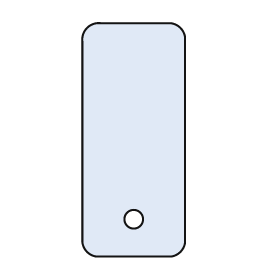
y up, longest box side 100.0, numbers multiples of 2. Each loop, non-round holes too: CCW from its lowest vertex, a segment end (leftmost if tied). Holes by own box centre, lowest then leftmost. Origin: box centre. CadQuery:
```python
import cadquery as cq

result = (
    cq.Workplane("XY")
    .moveTo(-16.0, -50.0)
    .lineTo(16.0, -50.0)
    .threePointArc((20.0, -48.0), (22.0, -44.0))
    .lineTo(22.0, 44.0)
    .threePointArc((20.0, 48.0), (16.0, 50.0))
    .lineTo(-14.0, 50.0)
    .threePointArc((-20.0, 48.0), (-22.0, 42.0))
    .lineTo(-22.0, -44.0)
    .threePointArc((-20.0, -48.0), (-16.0, -50.0))
    .close()
    .moveTo(0.0, -34.0)
    .circle(4.0)
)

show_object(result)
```